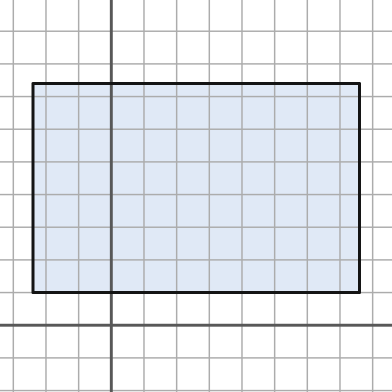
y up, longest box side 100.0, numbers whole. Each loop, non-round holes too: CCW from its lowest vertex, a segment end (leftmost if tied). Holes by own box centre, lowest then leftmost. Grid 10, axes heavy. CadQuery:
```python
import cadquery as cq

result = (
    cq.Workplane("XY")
    .moveTo(-24.0, 10.0)
    .lineTo(76.0, 10.0)
    .lineTo(76.0, 74.0)
    .lineTo(-24.0, 74.0)
    .close()
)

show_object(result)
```